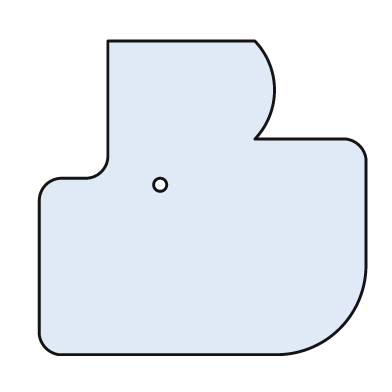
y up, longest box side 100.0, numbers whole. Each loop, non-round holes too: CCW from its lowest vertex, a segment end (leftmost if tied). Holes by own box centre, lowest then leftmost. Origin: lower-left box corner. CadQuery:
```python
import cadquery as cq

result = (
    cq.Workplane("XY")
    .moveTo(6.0, 0.0)
    .lineTo(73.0, 0.0)
    .threePointArc((92.0, 8.0), (100.0, 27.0))
    .lineTo(100.0, 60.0)
    .threePointArc((98.0, 64.0), (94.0, 66.0))
    .lineTo(66.0, 66.0)
    .threePointArc((72.0, 81.0), (66.0, 96.0))
    .lineTo(21.0, 96.0)
    .lineTo(21.0, 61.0)
    .threePointArc((19.0, 56.0), (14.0, 54.0))
    .lineTo(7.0, 54.0)
    .threePointArc((2.0, 52.0), (0.0, 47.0))
    .lineTo(0.0, 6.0)
    .threePointArc((2.0, 2.0), (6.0, 0.0))
    .close()
    .moveTo(37.0, 52.0)
    .circle(2.0)
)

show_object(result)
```